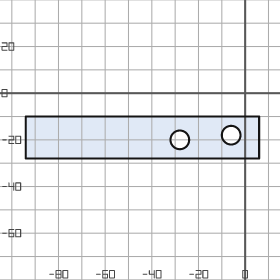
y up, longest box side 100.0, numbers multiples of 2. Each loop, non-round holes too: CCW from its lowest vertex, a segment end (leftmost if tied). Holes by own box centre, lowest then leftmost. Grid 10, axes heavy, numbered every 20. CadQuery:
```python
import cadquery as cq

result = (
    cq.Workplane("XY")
    .moveTo(-94.0, -28.0)
    .lineTo(6.0, -28.0)
    .lineTo(6.0, -10.0)
    .lineTo(-94.0, -10.0)
    .close()
    .moveTo(-28.0, -20.0)
    .circle(4.0)
    .moveTo(-6.0, -18.0)
    .circle(4.0)
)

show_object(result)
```